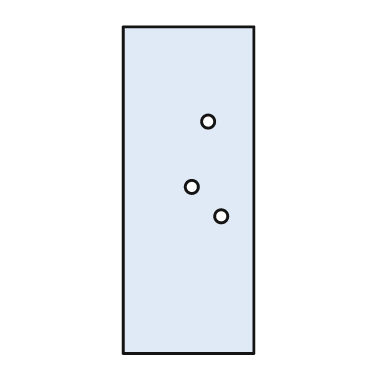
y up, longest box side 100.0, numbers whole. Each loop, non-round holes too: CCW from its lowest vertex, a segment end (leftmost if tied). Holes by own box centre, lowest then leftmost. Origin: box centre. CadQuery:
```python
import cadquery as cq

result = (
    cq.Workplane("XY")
    .moveTo(-20.0, -50.0)
    .lineTo(20.0, -50.0)
    .lineTo(20.0, 50.0)
    .lineTo(-20.0, 50.0)
    .close()
    .moveTo(10.0, -8.0)
    .circle(2.0)
    .moveTo(1.0, 1.0)
    .circle(2.0)
    .moveTo(6.0, 21.0)
    .circle(2.0)
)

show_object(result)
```